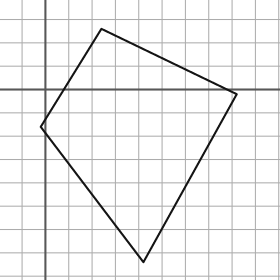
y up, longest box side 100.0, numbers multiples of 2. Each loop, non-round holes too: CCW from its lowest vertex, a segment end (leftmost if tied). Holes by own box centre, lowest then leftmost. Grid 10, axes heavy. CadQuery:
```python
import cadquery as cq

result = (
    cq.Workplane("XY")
    .moveTo(42.0, -74.0)
    .lineTo(82.0, -2.0)
    .lineTo(24.0, 26.0)
    .lineTo(-2.0, -16.0)
    .close()
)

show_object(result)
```